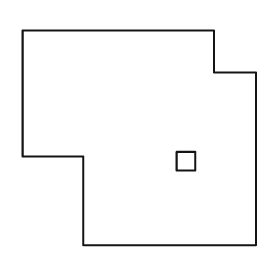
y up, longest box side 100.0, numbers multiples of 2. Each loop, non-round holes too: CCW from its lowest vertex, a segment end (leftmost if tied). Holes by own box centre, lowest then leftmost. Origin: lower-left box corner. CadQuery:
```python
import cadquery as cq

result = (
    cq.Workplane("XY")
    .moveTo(26.0, 0.0)
    .lineTo(100.0, 0.0)
    .lineTo(100.0, 74.0)
    .lineTo(82.0, 74.0)
    .lineTo(82.0, 92.0)
    .lineTo(0.0, 92.0)
    .lineTo(0.0, 38.0)
    .lineTo(26.0, 38.0)
    .close()
    .moveTo(66.0, 32.0)
    .lineTo(74.0, 32.0)
    .lineTo(74.0, 40.0)
    .lineTo(66.0, 40.0)
    .close()
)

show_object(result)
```